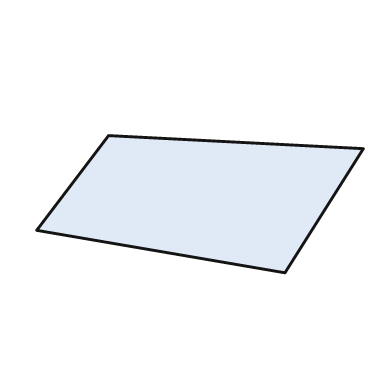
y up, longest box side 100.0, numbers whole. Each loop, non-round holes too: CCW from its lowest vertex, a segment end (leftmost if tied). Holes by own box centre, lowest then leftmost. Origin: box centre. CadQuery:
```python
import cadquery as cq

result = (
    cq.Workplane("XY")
    .moveTo(26.0, -21.0)
    .lineTo(50.0, 17.0)
    .lineTo(-28.0, 21.0)
    .lineTo(-50.0, -8.0)
    .close()
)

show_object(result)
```